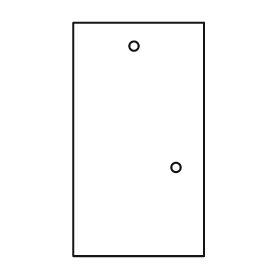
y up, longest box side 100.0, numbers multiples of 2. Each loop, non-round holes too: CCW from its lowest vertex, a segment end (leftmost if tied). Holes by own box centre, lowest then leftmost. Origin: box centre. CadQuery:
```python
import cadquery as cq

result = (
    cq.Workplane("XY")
    .moveTo(-28.0, -50.0)
    .lineTo(28.0, -50.0)
    .lineTo(28.0, 50.0)
    .lineTo(-28.0, 50.0)
    .close()
    .moveTo(16.0, -12.0)
    .circle(2.0)
    .moveTo(-2.0, 40.0)
    .circle(2.0)
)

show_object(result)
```